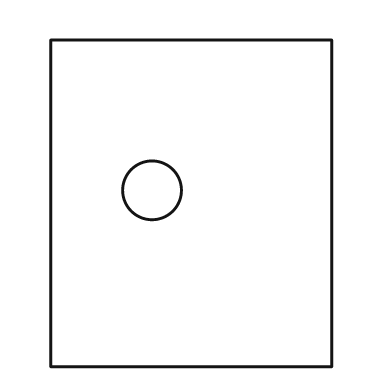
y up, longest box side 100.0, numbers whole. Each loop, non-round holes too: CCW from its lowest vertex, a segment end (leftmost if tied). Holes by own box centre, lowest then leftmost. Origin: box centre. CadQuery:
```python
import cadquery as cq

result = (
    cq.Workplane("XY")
    .moveTo(-43.0, -50.0)
    .lineTo(43.0, -50.0)
    .lineTo(43.0, 50.0)
    .lineTo(-43.0, 50.0)
    .close()
    .moveTo(-12.0, 4.0)
    .circle(9.0)
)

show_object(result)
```